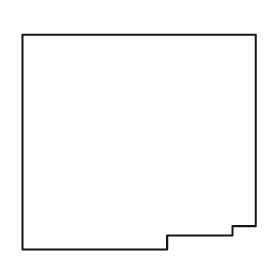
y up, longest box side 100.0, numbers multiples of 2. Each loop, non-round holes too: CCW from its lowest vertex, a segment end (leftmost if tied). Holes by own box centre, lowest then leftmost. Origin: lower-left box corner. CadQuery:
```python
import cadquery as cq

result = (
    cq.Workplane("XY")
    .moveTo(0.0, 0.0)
    .lineTo(62.0, 0.0)
    .lineTo(62.0, 6.0)
    .lineTo(90.0, 6.0)
    .lineTo(90.0, 10.0)
    .lineTo(100.0, 10.0)
    .lineTo(100.0, 92.0)
    .lineTo(0.0, 92.0)
    .close()
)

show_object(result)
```